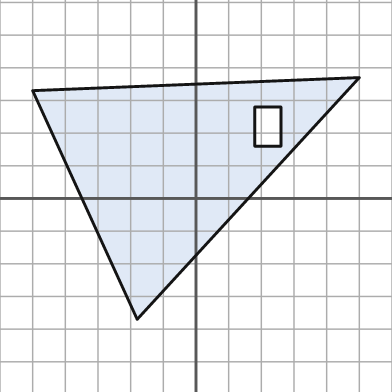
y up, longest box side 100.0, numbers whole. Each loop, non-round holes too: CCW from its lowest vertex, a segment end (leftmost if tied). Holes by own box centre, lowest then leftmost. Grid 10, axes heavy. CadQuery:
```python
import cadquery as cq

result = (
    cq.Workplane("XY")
    .moveTo(-18.0, -37.0)
    .lineTo(50.0, 37.0)
    .lineTo(-50.0, 33.0)
    .close()
    .moveTo(18.0, 16.0)
    .lineTo(26.0, 16.0)
    .lineTo(26.0, 28.0)
    .lineTo(18.0, 28.0)
    .close()
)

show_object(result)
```